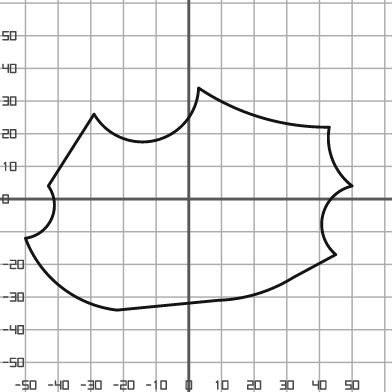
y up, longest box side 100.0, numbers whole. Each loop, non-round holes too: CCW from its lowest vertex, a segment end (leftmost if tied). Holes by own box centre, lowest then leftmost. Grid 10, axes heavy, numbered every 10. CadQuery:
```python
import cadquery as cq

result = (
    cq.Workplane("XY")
    .moveTo(-22.0, -34.0)
    .lineTo(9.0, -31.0)
    .threePointArc((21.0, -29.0), (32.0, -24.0))
    .lineTo(45.0, -17.0)
    .threePointArc((41.0, -5.0), (50.0, 4.0))
    .threePointArc((44.0, 12.0), (43.0, 22.0))
    .threePointArc((22.0, 25.0), (3.0, 34.0))
    .threePointArc((-10.0, 18.0), (-29.0, 26.0))
    .lineTo(-43.0, 4.0)
    .threePointArc((-42.0, -6.0), (-50.0, -12.0))
    .threePointArc((-39.0, -27.0), (-22.0, -34.0))
    .close()
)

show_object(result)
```